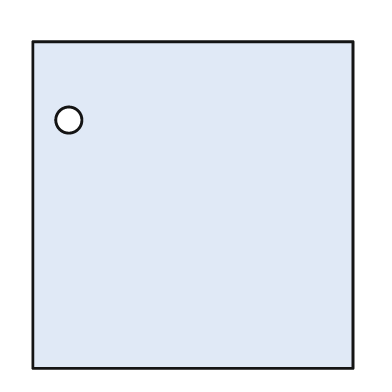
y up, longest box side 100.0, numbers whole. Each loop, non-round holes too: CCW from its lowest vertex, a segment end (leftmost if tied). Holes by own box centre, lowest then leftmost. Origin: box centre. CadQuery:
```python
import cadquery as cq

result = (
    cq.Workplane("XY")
    .moveTo(-49.0, -50.0)
    .lineTo(49.0, -50.0)
    .lineTo(49.0, 50.0)
    .lineTo(-49.0, 50.0)
    .close()
    .moveTo(-38.0, 26.0)
    .circle(4.0)
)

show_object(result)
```